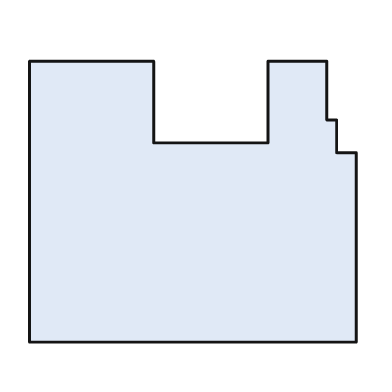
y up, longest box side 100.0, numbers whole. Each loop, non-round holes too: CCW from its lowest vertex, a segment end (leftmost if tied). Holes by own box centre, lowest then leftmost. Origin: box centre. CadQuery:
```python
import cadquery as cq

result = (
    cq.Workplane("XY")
    .moveTo(-50.0, -43.0)
    .lineTo(50.0, -43.0)
    .lineTo(50.0, 15.0)
    .lineTo(44.0, 15.0)
    .lineTo(44.0, 25.0)
    .lineTo(41.0, 25.0)
    .lineTo(41.0, 43.0)
    .lineTo(23.0, 43.0)
    .lineTo(23.0, 18.0)
    .lineTo(-12.0, 18.0)
    .lineTo(-12.0, 43.0)
    .lineTo(-50.0, 43.0)
    .close()
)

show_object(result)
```